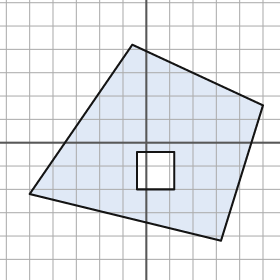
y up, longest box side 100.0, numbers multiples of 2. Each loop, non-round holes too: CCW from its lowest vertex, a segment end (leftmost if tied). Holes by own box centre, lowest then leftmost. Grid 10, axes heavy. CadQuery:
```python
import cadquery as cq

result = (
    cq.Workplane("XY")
    .moveTo(32.0, -42.0)
    .lineTo(50.0, 16.0)
    .lineTo(-6.0, 42.0)
    .lineTo(-50.0, -22.0)
    .close()
    .moveTo(-4.0, -20.0)
    .lineTo(12.0, -20.0)
    .lineTo(12.0, -4.0)
    .lineTo(-4.0, -4.0)
    .close()
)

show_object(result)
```